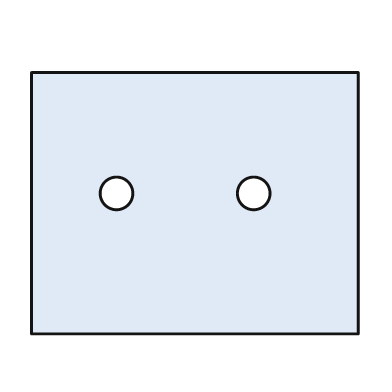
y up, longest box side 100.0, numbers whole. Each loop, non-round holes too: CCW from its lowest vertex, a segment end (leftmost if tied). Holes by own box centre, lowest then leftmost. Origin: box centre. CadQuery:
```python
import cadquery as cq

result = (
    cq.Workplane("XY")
    .moveTo(-50.0, -40.0)
    .lineTo(50.0, -40.0)
    .lineTo(50.0, 40.0)
    .lineTo(-50.0, 40.0)
    .close()
    .moveTo(-24.0, 3.0)
    .circle(5.0)
    .moveTo(18.0, 3.0)
    .circle(5.0)
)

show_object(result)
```